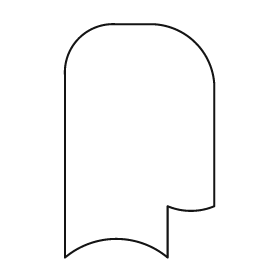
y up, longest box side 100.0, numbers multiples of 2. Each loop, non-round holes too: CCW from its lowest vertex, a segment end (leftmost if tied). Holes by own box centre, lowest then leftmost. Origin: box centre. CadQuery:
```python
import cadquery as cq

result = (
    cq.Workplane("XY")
    .moveTo(-32.0, -50.0)
    .threePointArc((-10.0, -42.0), (12.0, -50.0))
    .lineTo(12.0, -28.0)
    .threePointArc((22.0, -30.0), (32.0, -28.0))
    .lineTo(32.0, 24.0)
    .threePointArc((24.0, 42.0), (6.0, 50.0))
    .lineTo(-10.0, 50.0)
    .threePointArc((-26.0, 44.0), (-32.0, 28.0))
    .close()
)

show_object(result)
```